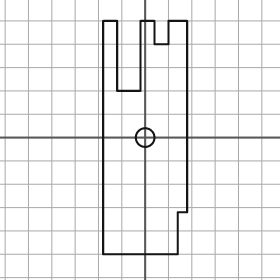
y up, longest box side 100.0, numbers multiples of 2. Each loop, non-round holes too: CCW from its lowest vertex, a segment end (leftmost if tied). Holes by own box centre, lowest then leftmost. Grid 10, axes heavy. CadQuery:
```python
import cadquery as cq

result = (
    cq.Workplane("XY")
    .moveTo(-18.0, -50.0)
    .lineTo(14.0, -50.0)
    .lineTo(14.0, -32.0)
    .lineTo(18.0, -32.0)
    .lineTo(18.0, 50.0)
    .lineTo(10.0, 50.0)
    .lineTo(10.0, 40.0)
    .lineTo(4.0, 40.0)
    .lineTo(4.0, 50.0)
    .lineTo(-2.0, 50.0)
    .lineTo(-2.0, 20.0)
    .lineTo(-12.0, 20.0)
    .lineTo(-12.0, 50.0)
    .lineTo(-18.0, 50.0)
    .close()
    .moveTo(0.0, 0.0)
    .circle(4.0)
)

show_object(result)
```